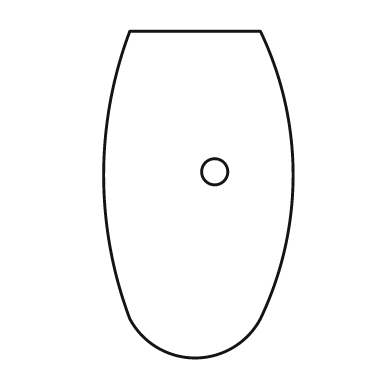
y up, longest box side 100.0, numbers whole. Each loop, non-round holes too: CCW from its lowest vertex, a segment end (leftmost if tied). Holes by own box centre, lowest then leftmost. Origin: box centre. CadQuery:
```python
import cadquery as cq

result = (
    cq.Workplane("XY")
    .moveTo(-21.0, -38.0)
    .threePointArc((-1.0, -50.0), (19.0, -38.0))
    .threePointArc((29.0, 6.0), (19.0, 50.0))
    .lineTo(-21.0, 50.0)
    .threePointArc((-29.0, 6.0), (-21.0, -38.0))
    .close()
    .moveTo(5.0, 7.0)
    .circle(4.0)
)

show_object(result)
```